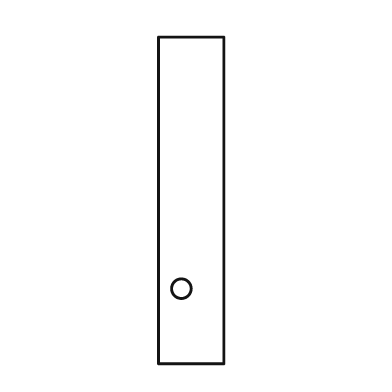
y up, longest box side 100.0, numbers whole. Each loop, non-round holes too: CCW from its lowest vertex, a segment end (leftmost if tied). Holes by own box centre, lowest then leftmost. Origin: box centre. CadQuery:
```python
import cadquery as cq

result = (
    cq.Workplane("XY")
    .moveTo(-10.0, -50.0)
    .lineTo(10.0, -50.0)
    .lineTo(10.0, 50.0)
    .lineTo(-10.0, 50.0)
    .close()
    .moveTo(-3.0, -27.0)
    .circle(3.0)
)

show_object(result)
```